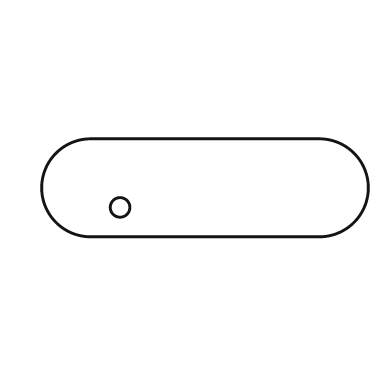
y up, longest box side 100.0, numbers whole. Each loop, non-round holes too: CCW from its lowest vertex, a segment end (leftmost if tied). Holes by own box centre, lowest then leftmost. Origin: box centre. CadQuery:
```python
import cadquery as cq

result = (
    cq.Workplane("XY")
    .moveTo(-35.0, -15.0)
    .lineTo(35.0, -15.0)
    .threePointArc((50.0, 0.0), (35.0, 15.0))
    .lineTo(-35.0, 15.0)
    .threePointArc((-50.0, 0.0), (-35.0, -15.0))
    .close()
    .moveTo(-26.0, -6.0)
    .circle(3.0)
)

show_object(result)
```